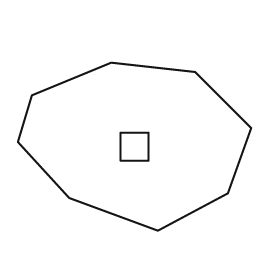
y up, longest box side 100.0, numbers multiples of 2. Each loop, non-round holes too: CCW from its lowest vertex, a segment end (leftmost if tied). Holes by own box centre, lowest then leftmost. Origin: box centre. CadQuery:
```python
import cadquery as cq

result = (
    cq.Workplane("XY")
    .moveTo(10.0, -36.0)
    .lineTo(40.0, -20.0)
    .lineTo(50.0, 8.0)
    .lineTo(26.0, 32.0)
    .lineTo(-10.0, 36.0)
    .lineTo(-44.0, 22.0)
    .lineTo(-50.0, 2.0)
    .lineTo(-28.0, -22.0)
    .close()
    .moveTo(-6.0, -6.0)
    .lineTo(6.0, -6.0)
    .lineTo(6.0, 6.0)
    .lineTo(-6.0, 6.0)
    .close()
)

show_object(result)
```